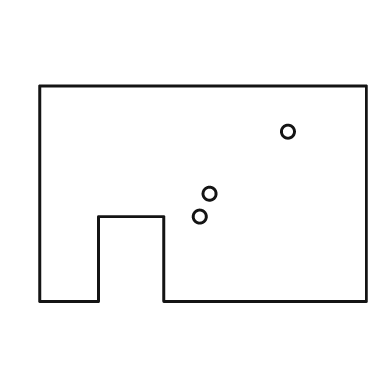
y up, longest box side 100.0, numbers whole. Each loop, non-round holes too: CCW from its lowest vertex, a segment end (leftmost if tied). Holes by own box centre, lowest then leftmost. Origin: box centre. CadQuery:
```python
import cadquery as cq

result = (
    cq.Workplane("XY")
    .moveTo(-50.0, -33.0)
    .lineTo(-32.0, -33.0)
    .lineTo(-32.0, -7.0)
    .lineTo(-12.0, -7.0)
    .lineTo(-12.0, -33.0)
    .lineTo(50.0, -33.0)
    .lineTo(50.0, 33.0)
    .lineTo(-50.0, 33.0)
    .close()
    .moveTo(-1.0, -7.0)
    .circle(2.0)
    .moveTo(2.0, 0.0)
    .circle(2.0)
    .moveTo(26.0, 19.0)
    .circle(2.0)
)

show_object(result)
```